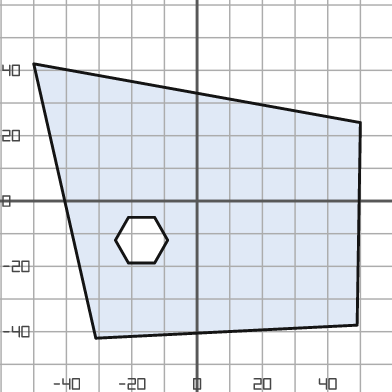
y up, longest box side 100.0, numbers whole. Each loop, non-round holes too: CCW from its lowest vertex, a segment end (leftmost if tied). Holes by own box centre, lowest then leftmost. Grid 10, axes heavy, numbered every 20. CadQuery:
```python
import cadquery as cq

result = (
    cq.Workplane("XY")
    .moveTo(-31.0, -42.0)
    .lineTo(49.0, -38.0)
    .lineTo(50.0, 24.0)
    .lineTo(-50.0, 42.0)
    .close()
    .moveTo(-21.0, -19.0)
    .lineTo(-13.0, -19.0)
    .lineTo(-9.0, -12.0)
    .lineTo(-13.0, -5.0)
    .lineTo(-21.0, -5.0)
    .lineTo(-25.0, -12.0)
    .close()
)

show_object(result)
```